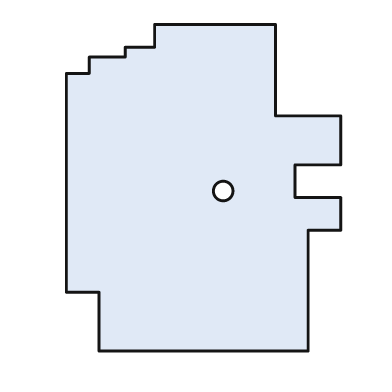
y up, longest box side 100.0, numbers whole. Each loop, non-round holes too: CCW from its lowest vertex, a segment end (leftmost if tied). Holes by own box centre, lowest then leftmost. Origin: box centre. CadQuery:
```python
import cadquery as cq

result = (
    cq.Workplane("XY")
    .moveTo(-32.0, -50.0)
    .lineTo(32.0, -50.0)
    .lineTo(32.0, -13.0)
    .lineTo(42.0, -13.0)
    .lineTo(42.0, -3.0)
    .lineTo(28.0, -3.0)
    .lineTo(28.0, 7.0)
    .lineTo(42.0, 7.0)
    .lineTo(42.0, 22.0)
    .lineTo(22.0, 22.0)
    .lineTo(22.0, 50.0)
    .lineTo(-15.0, 50.0)
    .lineTo(-15.0, 43.0)
    .lineTo(-24.0, 43.0)
    .lineTo(-24.0, 40.0)
    .lineTo(-35.0, 40.0)
    .lineTo(-35.0, 35.0)
    .lineTo(-42.0, 35.0)
    .lineTo(-42.0, -32.0)
    .lineTo(-32.0, -32.0)
    .close()
    .moveTo(6.0, -1.0)
    .circle(3.0)
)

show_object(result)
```